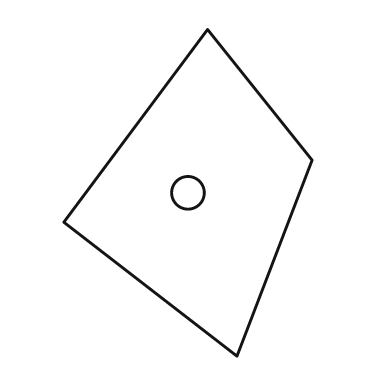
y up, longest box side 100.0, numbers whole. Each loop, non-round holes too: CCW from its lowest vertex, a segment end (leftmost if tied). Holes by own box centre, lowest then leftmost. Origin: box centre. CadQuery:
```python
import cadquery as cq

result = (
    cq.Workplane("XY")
    .moveTo(15.0, -50.0)
    .lineTo(38.0, 10.0)
    .lineTo(6.0, 50.0)
    .lineTo(-38.0, -9.0)
    .close()
    .moveTo(0.0, 0.0)
    .circle(5.0)
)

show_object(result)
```